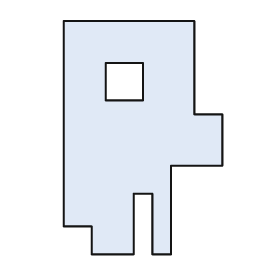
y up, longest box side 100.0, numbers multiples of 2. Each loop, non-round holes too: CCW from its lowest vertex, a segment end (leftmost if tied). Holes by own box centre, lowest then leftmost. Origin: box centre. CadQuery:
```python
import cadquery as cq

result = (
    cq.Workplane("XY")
    .moveTo(-22.0, -50.0)
    .lineTo(-4.0, -50.0)
    .lineTo(-4.0, -24.0)
    .lineTo(4.0, -24.0)
    .lineTo(4.0, -50.0)
    .lineTo(12.0, -50.0)
    .lineTo(12.0, -12.0)
    .lineTo(34.0, -12.0)
    .lineTo(34.0, 10.0)
    .lineTo(22.0, 10.0)
    .lineTo(22.0, 50.0)
    .lineTo(-34.0, 50.0)
    .lineTo(-34.0, -38.0)
    .lineTo(-22.0, -38.0)
    .close()
    .moveTo(-16.0, 16.0)
    .lineTo(0.0, 16.0)
    .lineTo(0.0, 32.0)
    .lineTo(-16.0, 32.0)
    .close()
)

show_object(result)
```